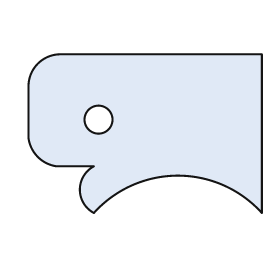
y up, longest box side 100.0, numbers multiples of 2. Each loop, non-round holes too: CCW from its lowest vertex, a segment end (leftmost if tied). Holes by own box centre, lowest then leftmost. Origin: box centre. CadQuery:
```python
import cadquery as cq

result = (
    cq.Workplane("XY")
    .moveTo(-22.0, -34.0)
    .threePointArc((14.0, -18.0), (50.0, -34.0))
    .lineTo(50.0, 34.0)
    .lineTo(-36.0, 34.0)
    .threePointArc((-46.0, 30.0), (-50.0, 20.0))
    .lineTo(-50.0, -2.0)
    .threePointArc((-46.0, -10.0), (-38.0, -14.0))
    .lineTo(-22.0, -14.0)
    .threePointArc((-28.0, -24.0), (-22.0, -34.0))
    .close()
    .moveTo(-20.0, 6.0)
    .circle(6.0)
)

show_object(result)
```